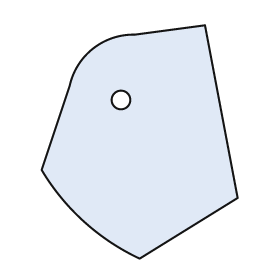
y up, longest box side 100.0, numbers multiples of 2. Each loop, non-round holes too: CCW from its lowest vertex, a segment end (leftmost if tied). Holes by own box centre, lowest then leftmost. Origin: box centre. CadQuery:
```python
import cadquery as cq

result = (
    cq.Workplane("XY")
    .moveTo(0.0, -50.0)
    .lineTo(42.0, -24.0)
    .lineTo(28.0, 50.0)
    .lineTo(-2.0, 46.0)
    .threePointArc((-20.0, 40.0), (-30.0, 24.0))
    .lineTo(-42.0, -12.0)
    .threePointArc((-24.0, -34.0), (0.0, -50.0))
    .close()
    .moveTo(-8.0, 18.0)
    .circle(4.0)
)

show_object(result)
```